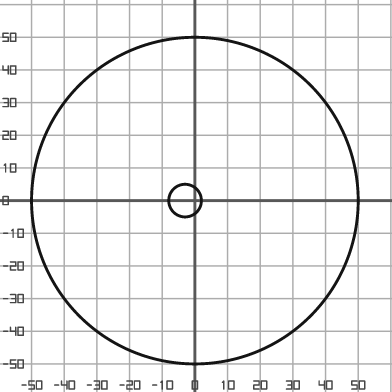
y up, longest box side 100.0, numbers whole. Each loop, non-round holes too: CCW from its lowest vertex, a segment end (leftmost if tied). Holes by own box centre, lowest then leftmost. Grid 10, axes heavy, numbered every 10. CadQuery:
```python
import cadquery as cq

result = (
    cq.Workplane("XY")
    .moveTo(0.0, 0.0)
    .circle(50.0)
    .moveTo(-3.0, 0.0)
    .circle(5.0)
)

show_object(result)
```